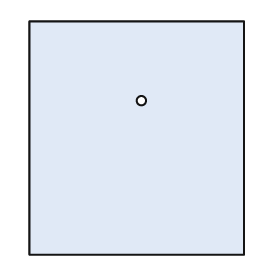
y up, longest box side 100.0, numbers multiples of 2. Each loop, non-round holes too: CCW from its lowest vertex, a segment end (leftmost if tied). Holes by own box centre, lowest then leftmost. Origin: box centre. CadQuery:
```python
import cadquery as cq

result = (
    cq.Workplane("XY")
    .moveTo(-46.0, -50.0)
    .lineTo(46.0, -50.0)
    .lineTo(46.0, 50.0)
    .lineTo(-46.0, 50.0)
    .close()
    .moveTo(2.0, 16.0)
    .circle(2.0)
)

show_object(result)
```